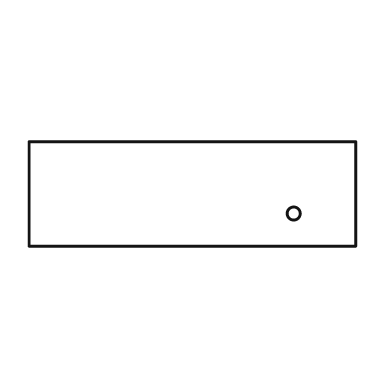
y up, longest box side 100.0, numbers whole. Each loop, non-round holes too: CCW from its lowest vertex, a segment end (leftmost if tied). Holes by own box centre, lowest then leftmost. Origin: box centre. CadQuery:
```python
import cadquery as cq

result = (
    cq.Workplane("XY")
    .moveTo(-50.0, -16.0)
    .lineTo(50.0, -16.0)
    .lineTo(50.0, 16.0)
    .lineTo(-50.0, 16.0)
    .close()
    .moveTo(31.0, -6.0)
    .circle(2.0)
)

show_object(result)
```